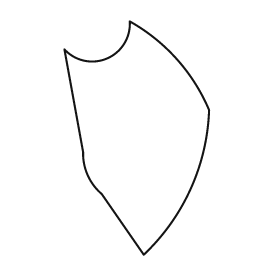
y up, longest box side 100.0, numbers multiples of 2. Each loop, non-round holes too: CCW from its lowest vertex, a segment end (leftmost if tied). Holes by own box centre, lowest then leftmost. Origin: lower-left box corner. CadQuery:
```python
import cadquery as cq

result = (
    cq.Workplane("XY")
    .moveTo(34.0, 0.0)
    .threePointArc((54.0, 28.0), (62.0, 62.0))
    .threePointArc((48.0, 84.0), (28.0, 100.0))
    .threePointArc((18.0, 84.0), (0.0, 88.0))
    .lineTo(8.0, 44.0)
    .threePointArc((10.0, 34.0), (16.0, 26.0))
    .close()
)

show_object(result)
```